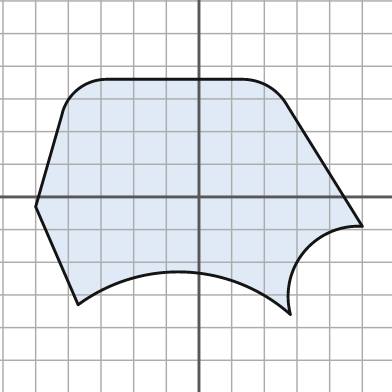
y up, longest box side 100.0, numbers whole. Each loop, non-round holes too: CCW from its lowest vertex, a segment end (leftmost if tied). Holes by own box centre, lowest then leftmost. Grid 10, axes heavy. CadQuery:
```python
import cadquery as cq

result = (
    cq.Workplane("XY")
    .moveTo(28.0, -36.0)
    .threePointArc((32.0, -17.0), (50.0, -9.0))
    .lineTo(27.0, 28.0)
    .threePointArc((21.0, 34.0), (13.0, 36.0))
    .lineTo(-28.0, 36.0)
    .threePointArc((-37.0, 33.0), (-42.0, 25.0))
    .lineTo(-50.0, -3.0)
    .lineTo(-37.0, -33.0)
    .threePointArc((-4.0, -23.0), (28.0, -36.0))
    .close()
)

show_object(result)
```